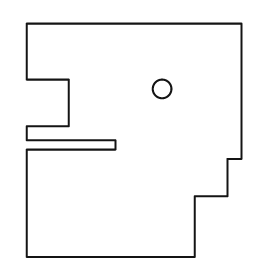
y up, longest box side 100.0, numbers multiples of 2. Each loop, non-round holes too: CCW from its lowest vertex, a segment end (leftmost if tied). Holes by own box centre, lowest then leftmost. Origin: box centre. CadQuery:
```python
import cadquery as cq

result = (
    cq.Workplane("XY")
    .moveTo(-46.0, -50.0)
    .lineTo(26.0, -50.0)
    .lineTo(26.0, -24.0)
    .lineTo(40.0, -24.0)
    .lineTo(40.0, -8.0)
    .lineTo(46.0, -8.0)
    .lineTo(46.0, 50.0)
    .lineTo(-46.0, 50.0)
    .lineTo(-46.0, 26.0)
    .lineTo(-28.0, 26.0)
    .lineTo(-28.0, 6.0)
    .lineTo(-46.0, 6.0)
    .lineTo(-46.0, 0.0)
    .lineTo(-8.0, 0.0)
    .lineTo(-8.0, -4.0)
    .lineTo(-46.0, -4.0)
    .close()
    .moveTo(12.0, 22.0)
    .circle(4.0)
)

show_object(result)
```